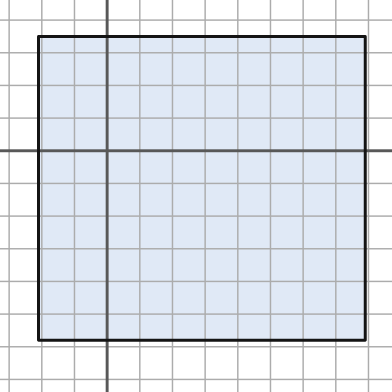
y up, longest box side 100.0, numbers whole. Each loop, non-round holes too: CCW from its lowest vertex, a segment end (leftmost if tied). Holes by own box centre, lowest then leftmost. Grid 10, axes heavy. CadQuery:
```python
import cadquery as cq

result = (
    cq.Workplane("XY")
    .moveTo(-21.0, -58.0)
    .lineTo(79.0, -58.0)
    .lineTo(79.0, 35.0)
    .lineTo(-21.0, 35.0)
    .close()
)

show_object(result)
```